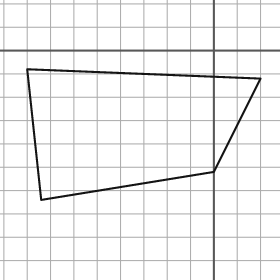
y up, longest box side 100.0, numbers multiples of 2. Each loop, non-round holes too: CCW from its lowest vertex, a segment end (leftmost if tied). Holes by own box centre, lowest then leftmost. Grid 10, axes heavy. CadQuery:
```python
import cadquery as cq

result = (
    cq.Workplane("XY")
    .moveTo(-74.0, -64.0)
    .lineTo(0.0, -52.0)
    .lineTo(20.0, -12.0)
    .lineTo(-80.0, -8.0)
    .close()
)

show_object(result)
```